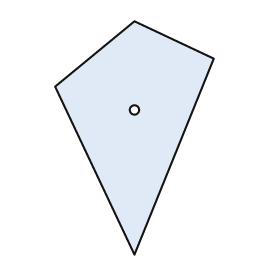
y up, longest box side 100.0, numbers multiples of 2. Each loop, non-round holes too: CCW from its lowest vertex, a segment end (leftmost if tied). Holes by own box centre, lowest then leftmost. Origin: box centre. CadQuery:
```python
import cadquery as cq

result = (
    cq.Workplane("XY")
    .moveTo(0.0, -50.0)
    .lineTo(34.0, 34.0)
    .lineTo(0.0, 50.0)
    .lineTo(-34.0, 22.0)
    .close()
    .moveTo(0.0, 12.0)
    .circle(2.0)
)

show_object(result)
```